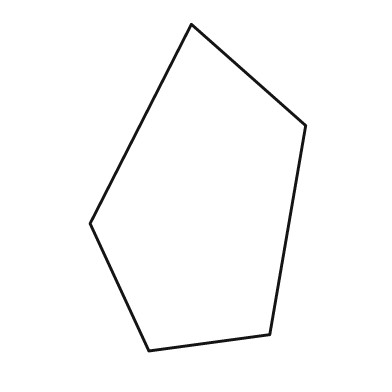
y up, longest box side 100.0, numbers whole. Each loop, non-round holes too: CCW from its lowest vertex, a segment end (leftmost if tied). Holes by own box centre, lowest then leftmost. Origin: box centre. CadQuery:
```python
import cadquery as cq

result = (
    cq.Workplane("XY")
    .moveTo(-15.0, -50.0)
    .lineTo(22.0, -45.0)
    .lineTo(33.0, 19.0)
    .lineTo(-2.0, 50.0)
    .lineTo(-33.0, -11.0)
    .close()
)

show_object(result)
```